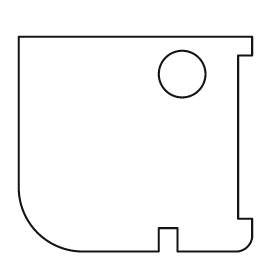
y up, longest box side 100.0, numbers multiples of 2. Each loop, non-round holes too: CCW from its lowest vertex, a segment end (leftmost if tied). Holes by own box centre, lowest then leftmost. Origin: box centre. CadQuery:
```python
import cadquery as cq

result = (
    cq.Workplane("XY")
    .moveTo(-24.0, -46.0)
    .lineTo(10.0, -46.0)
    .lineTo(10.0, -36.0)
    .lineTo(18.0, -36.0)
    .lineTo(18.0, -46.0)
    .lineTo(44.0, -46.0)
    .threePointArc((48.0, -44.0), (50.0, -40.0))
    .lineTo(50.0, -32.0)
    .lineTo(44.0, -32.0)
    .lineTo(44.0, 38.0)
    .lineTo(50.0, 38.0)
    .lineTo(50.0, 46.0)
    .lineTo(-50.0, 46.0)
    .lineTo(-50.0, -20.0)
    .threePointArc((-42.0, -38.0), (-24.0, -46.0))
    .close()
    .moveTo(20.0, 30.0)
    .circle(10.0)
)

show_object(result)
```